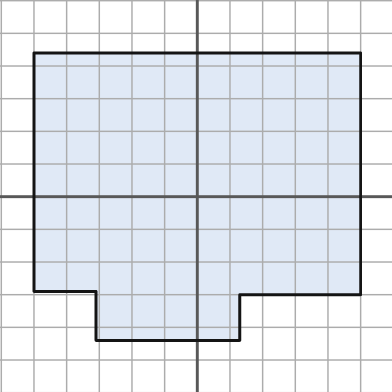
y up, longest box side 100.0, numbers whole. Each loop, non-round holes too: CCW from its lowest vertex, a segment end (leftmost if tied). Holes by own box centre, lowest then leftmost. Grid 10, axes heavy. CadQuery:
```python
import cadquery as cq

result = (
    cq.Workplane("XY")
    .moveTo(-31.0, -44.0)
    .lineTo(13.0, -44.0)
    .lineTo(13.0, -30.0)
    .lineTo(50.0, -30.0)
    .lineTo(50.0, 44.0)
    .lineTo(-50.0, 44.0)
    .lineTo(-50.0, -29.0)
    .lineTo(-31.0, -29.0)
    .close()
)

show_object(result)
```